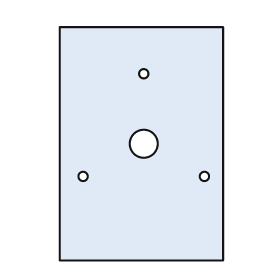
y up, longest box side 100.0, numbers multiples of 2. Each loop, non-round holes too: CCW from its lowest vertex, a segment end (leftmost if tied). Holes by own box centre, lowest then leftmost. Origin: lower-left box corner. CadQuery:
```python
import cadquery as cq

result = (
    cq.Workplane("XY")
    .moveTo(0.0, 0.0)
    .lineTo(70.0, 0.0)
    .lineTo(70.0, 100.0)
    .lineTo(0.0, 100.0)
    .close()
    .moveTo(10.0, 36.0)
    .circle(2.0)
    .moveTo(62.0, 36.0)
    .circle(2.0)
    .moveTo(36.0, 50.0)
    .circle(6.0)
    .moveTo(36.0, 80.0)
    .circle(2.0)
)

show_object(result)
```